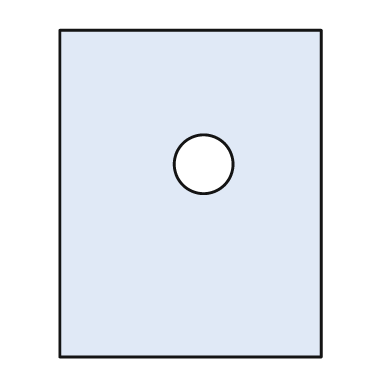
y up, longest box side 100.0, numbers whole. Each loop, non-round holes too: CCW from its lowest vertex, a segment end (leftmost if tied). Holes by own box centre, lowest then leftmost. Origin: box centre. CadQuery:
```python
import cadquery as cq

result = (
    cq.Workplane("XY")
    .moveTo(-40.0, -50.0)
    .lineTo(40.0, -50.0)
    .lineTo(40.0, 50.0)
    .lineTo(-40.0, 50.0)
    .close()
    .moveTo(4.0, 9.0)
    .circle(9.0)
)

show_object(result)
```